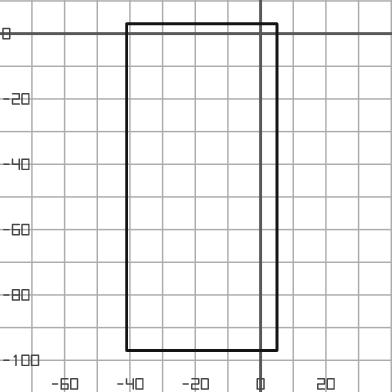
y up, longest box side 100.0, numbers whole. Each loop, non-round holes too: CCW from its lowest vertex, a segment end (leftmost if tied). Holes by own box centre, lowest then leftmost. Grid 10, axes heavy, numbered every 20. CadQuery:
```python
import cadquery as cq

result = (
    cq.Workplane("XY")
    .moveTo(-41.0, -97.0)
    .lineTo(5.0, -97.0)
    .lineTo(5.0, 3.0)
    .lineTo(-41.0, 3.0)
    .close()
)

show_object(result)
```